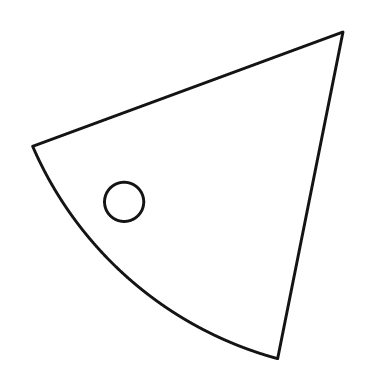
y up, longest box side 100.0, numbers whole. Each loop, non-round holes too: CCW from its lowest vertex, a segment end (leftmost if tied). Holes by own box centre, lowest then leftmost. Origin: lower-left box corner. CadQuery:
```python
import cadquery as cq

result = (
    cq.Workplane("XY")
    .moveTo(75.0, 0.0)
    .lineTo(95.0, 100.0)
    .lineTo(0.0, 65.0)
    .threePointArc((30.0, 24.0), (75.0, 0.0))
    .close()
    .moveTo(28.0, 48.0)
    .circle(6.0)
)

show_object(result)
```